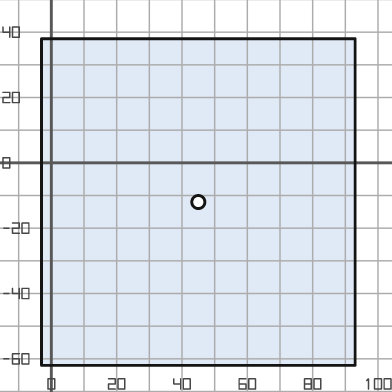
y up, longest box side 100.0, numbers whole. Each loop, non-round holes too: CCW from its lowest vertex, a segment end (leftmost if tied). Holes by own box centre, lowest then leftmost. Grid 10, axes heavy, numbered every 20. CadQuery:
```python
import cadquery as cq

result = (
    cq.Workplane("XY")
    .moveTo(-3.0, -62.0)
    .lineTo(93.0, -62.0)
    .lineTo(93.0, 38.0)
    .lineTo(-3.0, 38.0)
    .close()
    .moveTo(45.0, -12.0)
    .circle(2.0)
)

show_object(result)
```